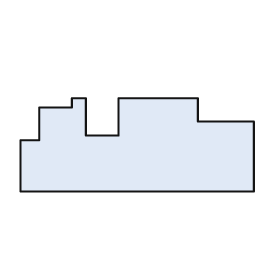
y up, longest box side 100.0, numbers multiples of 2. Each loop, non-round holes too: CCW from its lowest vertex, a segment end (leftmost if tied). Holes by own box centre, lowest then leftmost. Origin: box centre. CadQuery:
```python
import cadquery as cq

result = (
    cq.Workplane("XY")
    .moveTo(-50.0, -20.0)
    .lineTo(50.0, -20.0)
    .lineTo(50.0, 10.0)
    .lineTo(26.0, 10.0)
    .lineTo(26.0, 20.0)
    .lineTo(-8.0, 20.0)
    .lineTo(-8.0, 4.0)
    .lineTo(-22.0, 4.0)
    .lineTo(-22.0, 20.0)
    .lineTo(-28.0, 20.0)
    .lineTo(-28.0, 16.0)
    .lineTo(-42.0, 16.0)
    .lineTo(-42.0, 2.0)
    .lineTo(-50.0, 2.0)
    .close()
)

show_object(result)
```